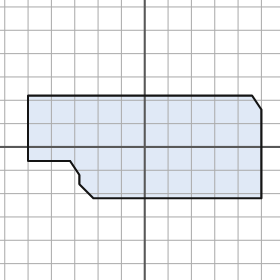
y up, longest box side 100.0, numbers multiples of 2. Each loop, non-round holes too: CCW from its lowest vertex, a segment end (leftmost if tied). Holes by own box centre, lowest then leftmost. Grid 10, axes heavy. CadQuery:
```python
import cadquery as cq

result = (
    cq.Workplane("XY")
    .moveTo(-22.0, -22.0)
    .lineTo(50.0, -22.0)
    .lineTo(50.0, 16.0)
    .lineTo(46.0, 22.0)
    .lineTo(-50.0, 22.0)
    .lineTo(-50.0, -6.0)
    .lineTo(-32.0, -6.0)
    .lineTo(-28.0, -12.0)
    .lineTo(-28.0, -16.0)
    .close()
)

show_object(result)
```